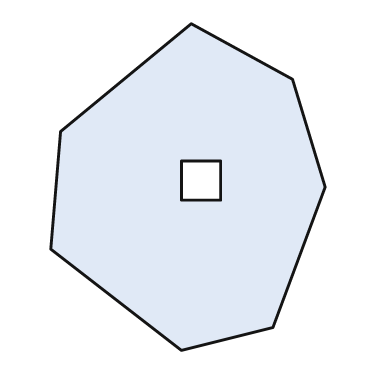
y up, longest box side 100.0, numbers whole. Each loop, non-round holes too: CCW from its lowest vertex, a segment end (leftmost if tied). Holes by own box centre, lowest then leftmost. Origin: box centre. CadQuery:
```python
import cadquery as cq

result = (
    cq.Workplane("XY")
    .moveTo(-2.0, -50.0)
    .lineTo(26.0, -43.0)
    .lineTo(42.0, 0.0)
    .lineTo(32.0, 33.0)
    .lineTo(1.0, 50.0)
    .lineTo(-39.0, 17.0)
    .lineTo(-42.0, -19.0)
    .close()
    .moveTo(-2.0, -4.0)
    .lineTo(10.0, -4.0)
    .lineTo(10.0, 8.0)
    .lineTo(-2.0, 8.0)
    .close()
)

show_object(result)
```